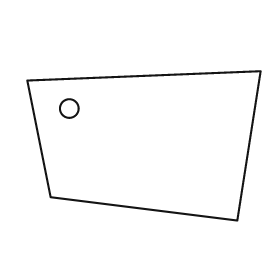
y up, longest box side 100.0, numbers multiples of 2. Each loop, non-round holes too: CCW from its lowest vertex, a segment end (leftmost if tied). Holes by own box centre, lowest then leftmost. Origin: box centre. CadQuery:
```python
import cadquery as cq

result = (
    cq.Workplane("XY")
    .moveTo(40.0, -32.0)
    .lineTo(50.0, 32.0)
    .lineTo(-50.0, 28.0)
    .lineTo(-40.0, -22.0)
    .close()
    .moveTo(-32.0, 16.0)
    .circle(4.0)
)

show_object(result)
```